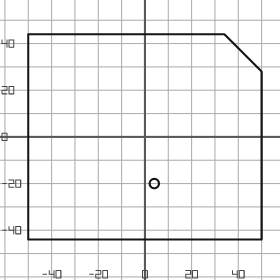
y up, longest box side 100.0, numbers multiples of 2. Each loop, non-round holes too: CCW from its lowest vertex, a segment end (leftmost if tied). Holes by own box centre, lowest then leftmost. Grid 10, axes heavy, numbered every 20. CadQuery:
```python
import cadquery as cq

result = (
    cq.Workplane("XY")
    .moveTo(-50.0, -44.0)
    .lineTo(50.0, -44.0)
    .lineTo(50.0, 28.0)
    .lineTo(34.0, 44.0)
    .lineTo(-50.0, 44.0)
    .close()
    .moveTo(4.0, -20.0)
    .circle(2.0)
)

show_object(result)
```